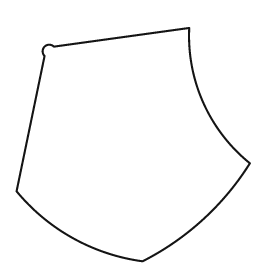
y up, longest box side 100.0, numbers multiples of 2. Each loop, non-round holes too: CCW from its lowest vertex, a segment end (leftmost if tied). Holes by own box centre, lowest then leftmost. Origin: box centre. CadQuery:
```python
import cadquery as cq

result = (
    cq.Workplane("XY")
    .moveTo(4.0, -50.0)
    .threePointArc((30.0, -32.0), (50.0, -8.0))
    .threePointArc((30.0, 18.0), (24.0, 50.0))
    .lineTo(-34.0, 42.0)
    .threePointArc((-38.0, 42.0), (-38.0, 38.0))
    .lineTo(-50.0, -20.0)
    .threePointArc((-26.0, -40.0), (4.0, -50.0))
    .close()
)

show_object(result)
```